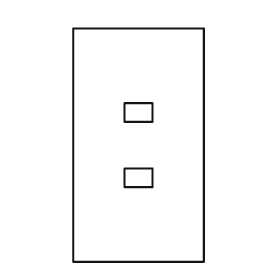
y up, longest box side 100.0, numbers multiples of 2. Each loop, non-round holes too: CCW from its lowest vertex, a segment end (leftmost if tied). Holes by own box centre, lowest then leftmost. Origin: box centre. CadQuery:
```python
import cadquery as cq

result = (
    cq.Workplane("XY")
    .moveTo(-28.0, -50.0)
    .lineTo(28.0, -50.0)
    .lineTo(28.0, 50.0)
    .lineTo(-28.0, 50.0)
    .close()
    .moveTo(-6.0, -18.0)
    .lineTo(6.0, -18.0)
    .lineTo(6.0, -10.0)
    .lineTo(-6.0, -10.0)
    .close()
    .moveTo(-6.0, 10.0)
    .lineTo(6.0, 10.0)
    .lineTo(6.0, 18.0)
    .lineTo(-6.0, 18.0)
    .close()
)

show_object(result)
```